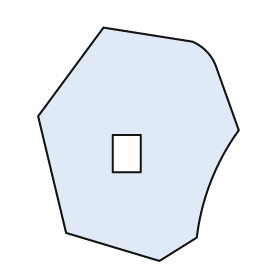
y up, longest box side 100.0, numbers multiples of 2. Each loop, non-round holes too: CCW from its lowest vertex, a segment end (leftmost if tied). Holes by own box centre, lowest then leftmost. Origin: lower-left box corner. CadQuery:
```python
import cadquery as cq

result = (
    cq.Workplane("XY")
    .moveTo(52.0, 0.0)
    .lineTo(68.0, 10.0)
    .threePointArc((74.0, 34.0), (86.0, 56.0))
    .lineTo(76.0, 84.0)
    .threePointArc((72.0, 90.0), (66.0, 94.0))
    .lineTo(28.0, 100.0)
    .lineTo(0.0, 62.0)
    .lineTo(12.0, 12.0)
    .close()
    .moveTo(32.0, 38.0)
    .lineTo(44.0, 38.0)
    .lineTo(44.0, 54.0)
    .lineTo(32.0, 54.0)
    .close()
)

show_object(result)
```